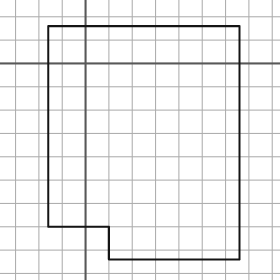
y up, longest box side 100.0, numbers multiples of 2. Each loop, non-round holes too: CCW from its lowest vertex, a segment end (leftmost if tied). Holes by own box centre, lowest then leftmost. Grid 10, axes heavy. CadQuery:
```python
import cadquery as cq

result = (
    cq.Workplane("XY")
    .moveTo(10.0, -84.0)
    .lineTo(66.0, -84.0)
    .lineTo(66.0, 16.0)
    .lineTo(-16.0, 16.0)
    .lineTo(-16.0, -70.0)
    .lineTo(10.0, -70.0)
    .close()
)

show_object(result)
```